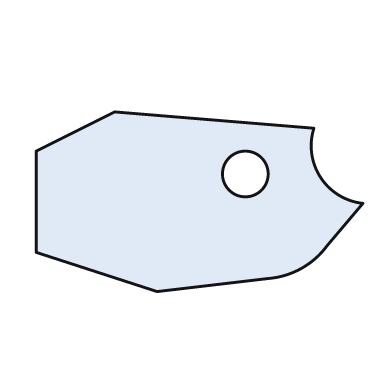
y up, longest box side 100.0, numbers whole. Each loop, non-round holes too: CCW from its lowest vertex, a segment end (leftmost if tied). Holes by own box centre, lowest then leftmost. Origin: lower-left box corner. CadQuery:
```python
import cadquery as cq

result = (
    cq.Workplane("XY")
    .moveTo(37.0, 0.0)
    .lineTo(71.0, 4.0)
    .threePointArc((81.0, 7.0), (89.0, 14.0))
    .lineTo(100.0, 27.0)
    .threePointArc((87.0, 35.0), (85.0, 50.0))
    .lineTo(24.0, 55.0)
    .lineTo(0.0, 43.0)
    .lineTo(0.0, 12.0)
    .close()
    .moveTo(64.0, 36.0)
    .circle(7.0)
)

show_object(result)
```